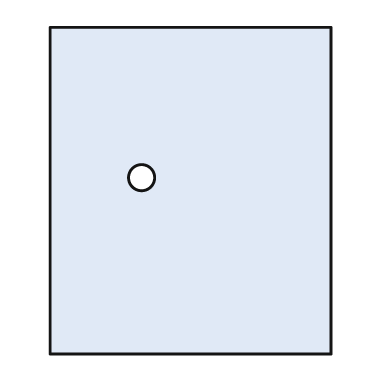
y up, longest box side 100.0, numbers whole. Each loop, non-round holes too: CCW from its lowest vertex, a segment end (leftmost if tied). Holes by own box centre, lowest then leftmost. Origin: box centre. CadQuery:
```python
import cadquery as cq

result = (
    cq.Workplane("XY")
    .moveTo(-43.0, -50.0)
    .lineTo(43.0, -50.0)
    .lineTo(43.0, 50.0)
    .lineTo(-43.0, 50.0)
    .close()
    .moveTo(-15.0, 4.0)
    .circle(4.0)
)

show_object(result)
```